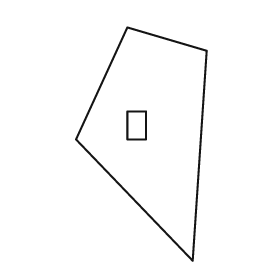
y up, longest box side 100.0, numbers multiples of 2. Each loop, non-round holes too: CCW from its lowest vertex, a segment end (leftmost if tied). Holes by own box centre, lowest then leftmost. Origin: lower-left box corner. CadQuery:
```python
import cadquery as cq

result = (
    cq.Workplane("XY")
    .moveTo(50.0, 0.0)
    .lineTo(56.0, 90.0)
    .lineTo(22.0, 100.0)
    .lineTo(0.0, 52.0)
    .close()
    .moveTo(22.0, 52.0)
    .lineTo(30.0, 52.0)
    .lineTo(30.0, 64.0)
    .lineTo(22.0, 64.0)
    .close()
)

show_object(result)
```